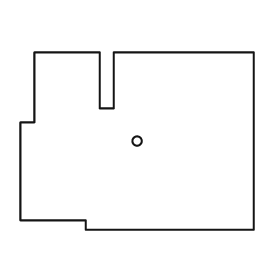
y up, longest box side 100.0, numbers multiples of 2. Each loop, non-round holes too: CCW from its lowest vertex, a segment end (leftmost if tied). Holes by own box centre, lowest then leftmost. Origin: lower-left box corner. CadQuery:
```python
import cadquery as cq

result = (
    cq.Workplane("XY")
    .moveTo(28.0, 0.0)
    .lineTo(100.0, 0.0)
    .lineTo(100.0, 76.0)
    .lineTo(40.0, 76.0)
    .lineTo(40.0, 52.0)
    .lineTo(34.0, 52.0)
    .lineTo(34.0, 76.0)
    .lineTo(6.0, 76.0)
    .lineTo(6.0, 46.0)
    .lineTo(0.0, 46.0)
    .lineTo(0.0, 4.0)
    .lineTo(28.0, 4.0)
    .close()
    .moveTo(50.0, 38.0)
    .circle(2.0)
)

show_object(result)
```